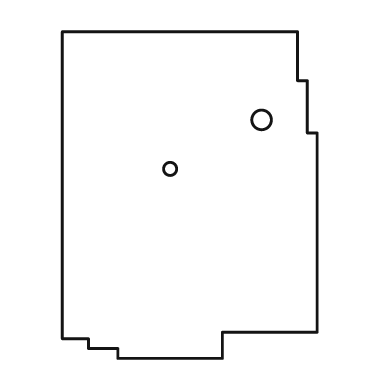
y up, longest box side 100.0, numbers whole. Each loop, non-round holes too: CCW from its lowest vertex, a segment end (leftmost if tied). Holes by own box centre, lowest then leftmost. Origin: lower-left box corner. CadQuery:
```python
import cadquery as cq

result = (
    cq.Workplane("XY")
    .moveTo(17.0, 0.0)
    .lineTo(49.0, 0.0)
    .lineTo(49.0, 8.0)
    .lineTo(78.0, 8.0)
    .lineTo(78.0, 69.0)
    .lineTo(75.0, 69.0)
    .lineTo(75.0, 85.0)
    .lineTo(72.0, 85.0)
    .lineTo(72.0, 100.0)
    .lineTo(0.0, 100.0)
    .lineTo(0.0, 6.0)
    .lineTo(8.0, 6.0)
    .lineTo(8.0, 3.0)
    .lineTo(17.0, 3.0)
    .close()
    .moveTo(33.0, 58.0)
    .circle(2.0)
    .moveTo(61.0, 73.0)
    .circle(3.0)
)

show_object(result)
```